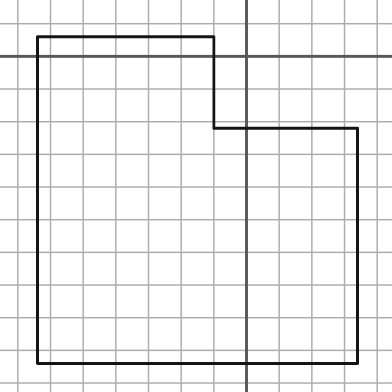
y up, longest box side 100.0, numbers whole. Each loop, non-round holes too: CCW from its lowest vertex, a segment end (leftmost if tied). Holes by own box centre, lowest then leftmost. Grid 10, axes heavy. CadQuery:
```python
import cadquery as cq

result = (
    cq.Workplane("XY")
    .moveTo(-64.0, -94.0)
    .lineTo(34.0, -94.0)
    .lineTo(34.0, -22.0)
    .lineTo(-10.0, -22.0)
    .lineTo(-10.0, 6.0)
    .lineTo(-64.0, 6.0)
    .close()
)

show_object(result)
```